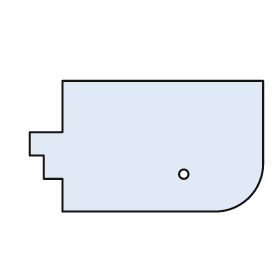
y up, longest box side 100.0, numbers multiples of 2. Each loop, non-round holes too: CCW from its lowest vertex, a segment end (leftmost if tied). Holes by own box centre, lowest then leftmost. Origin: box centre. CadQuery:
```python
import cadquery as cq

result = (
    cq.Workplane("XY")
    .moveTo(-36.0, -28.0)
    .lineTo(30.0, -28.0)
    .threePointArc((44.0, -22.0), (50.0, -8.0))
    .lineTo(50.0, 28.0)
    .lineTo(-36.0, 28.0)
    .lineTo(-36.0, 6.0)
    .lineTo(-50.0, 6.0)
    .lineTo(-50.0, -4.0)
    .lineTo(-44.0, -4.0)
    .lineTo(-44.0, -14.0)
    .lineTo(-36.0, -14.0)
    .close()
    .moveTo(16.0, -12.0)
    .circle(2.0)
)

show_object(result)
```